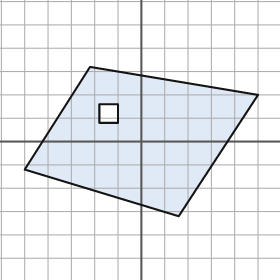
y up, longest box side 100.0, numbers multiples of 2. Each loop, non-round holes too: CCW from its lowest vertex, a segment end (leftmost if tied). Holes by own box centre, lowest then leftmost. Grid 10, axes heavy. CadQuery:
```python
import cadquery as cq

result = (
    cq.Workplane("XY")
    .moveTo(16.0, -32.0)
    .lineTo(50.0, 20.0)
    .lineTo(-22.0, 32.0)
    .lineTo(-50.0, -12.0)
    .close()
    .moveTo(-18.0, 8.0)
    .lineTo(-10.0, 8.0)
    .lineTo(-10.0, 16.0)
    .lineTo(-18.0, 16.0)
    .close()
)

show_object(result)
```